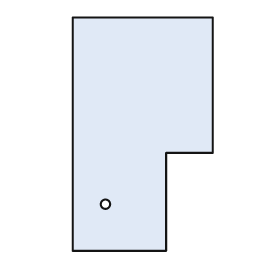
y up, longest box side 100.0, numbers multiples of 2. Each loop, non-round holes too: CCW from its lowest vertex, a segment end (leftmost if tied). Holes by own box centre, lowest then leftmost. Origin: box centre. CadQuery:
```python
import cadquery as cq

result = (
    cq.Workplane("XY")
    .moveTo(-30.0, -50.0)
    .lineTo(10.0, -50.0)
    .lineTo(10.0, -8.0)
    .lineTo(30.0, -8.0)
    .lineTo(30.0, 50.0)
    .lineTo(-30.0, 50.0)
    .close()
    .moveTo(-16.0, -30.0)
    .circle(2.0)
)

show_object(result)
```